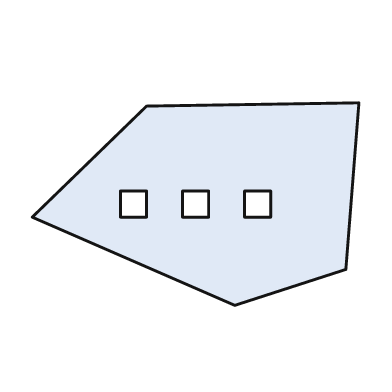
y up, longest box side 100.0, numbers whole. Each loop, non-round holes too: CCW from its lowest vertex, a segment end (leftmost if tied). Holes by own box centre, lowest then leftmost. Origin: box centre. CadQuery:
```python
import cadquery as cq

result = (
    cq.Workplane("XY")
    .moveTo(12.0, -31.0)
    .lineTo(46.0, -20.0)
    .lineTo(50.0, 31.0)
    .lineTo(-15.0, 30.0)
    .lineTo(-50.0, -4.0)
    .close()
    .moveTo(-23.0, -4.0)
    .lineTo(-15.0, -4.0)
    .lineTo(-15.0, 4.0)
    .lineTo(-23.0, 4.0)
    .close()
    .moveTo(-4.0, -4.0)
    .lineTo(4.0, -4.0)
    .lineTo(4.0, 4.0)
    .lineTo(-4.0, 4.0)
    .close()
    .moveTo(15.0, -4.0)
    .lineTo(23.0, -4.0)
    .lineTo(23.0, 4.0)
    .lineTo(15.0, 4.0)
    .close()
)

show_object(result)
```